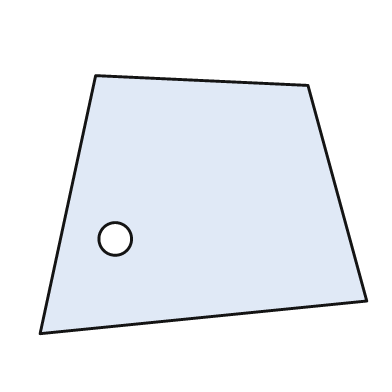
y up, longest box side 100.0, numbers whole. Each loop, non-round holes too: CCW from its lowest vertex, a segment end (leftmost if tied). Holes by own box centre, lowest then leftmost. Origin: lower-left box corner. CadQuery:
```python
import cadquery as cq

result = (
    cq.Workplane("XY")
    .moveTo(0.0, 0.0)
    .lineTo(100.0, 10.0)
    .lineTo(82.0, 76.0)
    .lineTo(17.0, 79.0)
    .close()
    .moveTo(23.0, 29.0)
    .circle(5.0)
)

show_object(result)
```